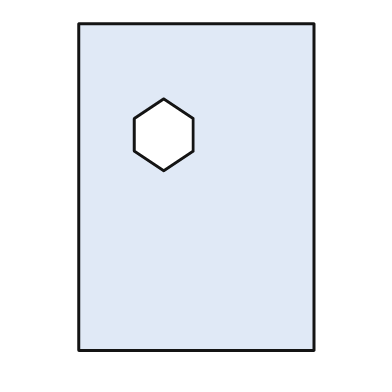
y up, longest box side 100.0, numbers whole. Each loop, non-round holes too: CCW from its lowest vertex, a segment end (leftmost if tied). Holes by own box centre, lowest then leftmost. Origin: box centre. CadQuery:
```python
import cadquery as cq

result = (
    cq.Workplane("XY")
    .moveTo(-36.0, -50.0)
    .lineTo(36.0, -50.0)
    .lineTo(36.0, 50.0)
    .lineTo(-36.0, 50.0)
    .close()
    .moveTo(-10.0, 5.0)
    .lineTo(-1.0, 11.0)
    .lineTo(-1.0, 21.0)
    .lineTo(-10.0, 27.0)
    .lineTo(-19.0, 21.0)
    .lineTo(-19.0, 11.0)
    .close()
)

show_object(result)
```